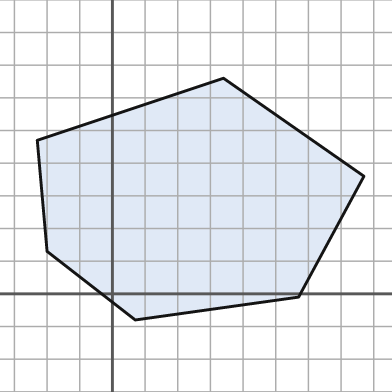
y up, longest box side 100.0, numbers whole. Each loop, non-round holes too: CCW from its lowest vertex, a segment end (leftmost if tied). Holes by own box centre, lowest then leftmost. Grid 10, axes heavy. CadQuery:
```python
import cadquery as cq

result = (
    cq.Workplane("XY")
    .moveTo(7.0, -8.0)
    .lineTo(57.0, -1.0)
    .lineTo(77.0, 36.0)
    .lineTo(34.0, 66.0)
    .lineTo(-23.0, 47.0)
    .lineTo(-20.0, 13.0)
    .close()
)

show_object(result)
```